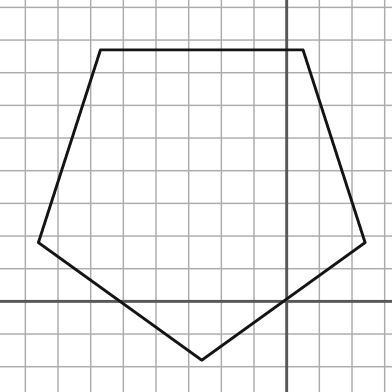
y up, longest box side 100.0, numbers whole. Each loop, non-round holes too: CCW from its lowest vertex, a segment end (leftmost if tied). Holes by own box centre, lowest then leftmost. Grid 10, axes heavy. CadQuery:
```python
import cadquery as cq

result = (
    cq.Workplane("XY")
    .moveTo(-26.0, -18.0)
    .lineTo(24.0, 18.0)
    .lineTo(5.0, 77.0)
    .lineTo(-57.0, 77.0)
    .lineTo(-76.0, 18.0)
    .close()
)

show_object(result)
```